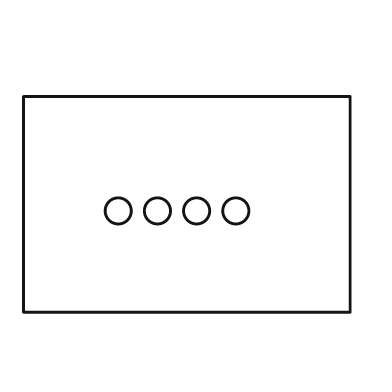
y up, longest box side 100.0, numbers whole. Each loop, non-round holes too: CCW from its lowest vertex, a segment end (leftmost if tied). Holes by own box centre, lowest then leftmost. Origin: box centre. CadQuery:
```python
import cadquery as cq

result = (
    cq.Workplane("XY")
    .moveTo(-50.0, -33.0)
    .lineTo(50.0, -33.0)
    .lineTo(50.0, 33.0)
    .lineTo(-50.0, 33.0)
    .close()
    .moveTo(-21.0, -2.0)
    .circle(4.0)
    .moveTo(-9.0, -2.0)
    .circle(4.0)
    .moveTo(3.0, -2.0)
    .circle(4.0)
    .moveTo(15.0, -2.0)
    .circle(4.0)
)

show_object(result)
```